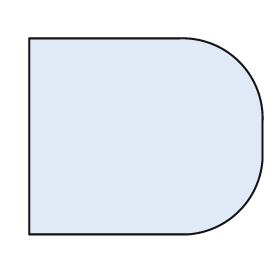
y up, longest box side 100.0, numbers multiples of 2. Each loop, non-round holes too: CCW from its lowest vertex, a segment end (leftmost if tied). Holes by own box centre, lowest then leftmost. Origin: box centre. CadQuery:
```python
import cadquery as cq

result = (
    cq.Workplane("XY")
    .moveTo(-50.0, -42.0)
    .lineTo(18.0, -42.0)
    .threePointArc((40.0, -32.0), (50.0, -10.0))
    .lineTo(50.0, 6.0)
    .threePointArc((40.0, 32.0), (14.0, 42.0))
    .lineTo(-50.0, 42.0)
    .close()
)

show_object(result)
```